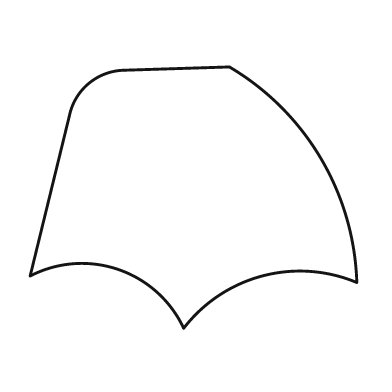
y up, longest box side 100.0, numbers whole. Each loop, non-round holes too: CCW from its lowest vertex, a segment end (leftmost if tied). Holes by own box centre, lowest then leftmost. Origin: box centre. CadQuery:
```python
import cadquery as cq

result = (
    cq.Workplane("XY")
    .moveTo(-3.0, -40.0)
    .threePointArc((21.0, -24.0), (50.0, -26.0))
    .threePointArc((39.0, 12.0), (11.0, 40.0))
    .lineTo(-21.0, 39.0)
    .threePointArc((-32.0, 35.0), (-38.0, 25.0))
    .lineTo(-50.0, -24.0)
    .threePointArc((-23.0, -22.0), (-3.0, -40.0))
    .close()
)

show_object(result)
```